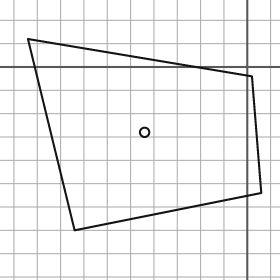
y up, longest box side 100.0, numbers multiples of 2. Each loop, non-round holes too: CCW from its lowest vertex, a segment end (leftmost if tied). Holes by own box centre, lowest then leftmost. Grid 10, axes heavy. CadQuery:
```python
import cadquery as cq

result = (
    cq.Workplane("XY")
    .moveTo(-74.0, -70.0)
    .lineTo(6.0, -54.0)
    .lineTo(2.0, -4.0)
    .lineTo(-94.0, 12.0)
    .close()
    .moveTo(-44.0, -28.0)
    .circle(2.0)
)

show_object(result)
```